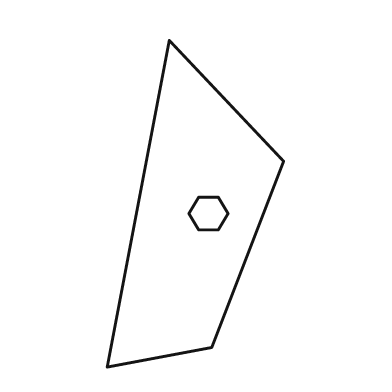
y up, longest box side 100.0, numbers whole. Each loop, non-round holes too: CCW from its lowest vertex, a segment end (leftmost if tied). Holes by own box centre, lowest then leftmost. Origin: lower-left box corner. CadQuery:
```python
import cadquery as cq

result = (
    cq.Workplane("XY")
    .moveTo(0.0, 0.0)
    .lineTo(32.0, 6.0)
    .lineTo(54.0, 63.0)
    .lineTo(19.0, 100.0)
    .close()
    .moveTo(28.0, 42.0)
    .lineTo(34.0, 42.0)
    .lineTo(37.0, 47.0)
    .lineTo(34.0, 52.0)
    .lineTo(28.0, 52.0)
    .lineTo(25.0, 47.0)
    .close()
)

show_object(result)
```